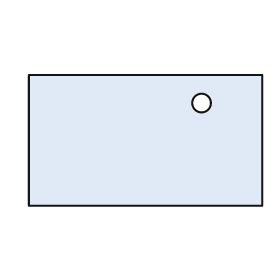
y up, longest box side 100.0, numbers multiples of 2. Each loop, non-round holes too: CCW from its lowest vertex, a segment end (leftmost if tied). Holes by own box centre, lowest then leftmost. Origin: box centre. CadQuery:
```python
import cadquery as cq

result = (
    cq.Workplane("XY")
    .moveTo(-50.0, -28.0)
    .lineTo(50.0, -28.0)
    .lineTo(50.0, 28.0)
    .lineTo(-50.0, 28.0)
    .close()
    .moveTo(24.0, 16.0)
    .circle(4.0)
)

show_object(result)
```